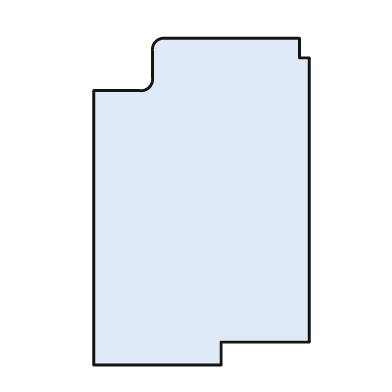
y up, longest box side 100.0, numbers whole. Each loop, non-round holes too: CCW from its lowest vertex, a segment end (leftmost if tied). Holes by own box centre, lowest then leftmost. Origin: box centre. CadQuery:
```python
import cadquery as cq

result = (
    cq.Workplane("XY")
    .moveTo(-33.0, -50.0)
    .lineTo(6.0, -50.0)
    .lineTo(6.0, -43.0)
    .lineTo(33.0, -43.0)
    .lineTo(33.0, 44.0)
    .lineTo(30.0, 44.0)
    .lineTo(30.0, 50.0)
    .lineTo(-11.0, 50.0)
    .threePointArc((-14.0, 49.0), (-15.0, 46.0))
    .lineTo(-15.0, 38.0)
    .threePointArc((-16.0, 35.0), (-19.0, 34.0))
    .lineTo(-33.0, 34.0)
    .close()
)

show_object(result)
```